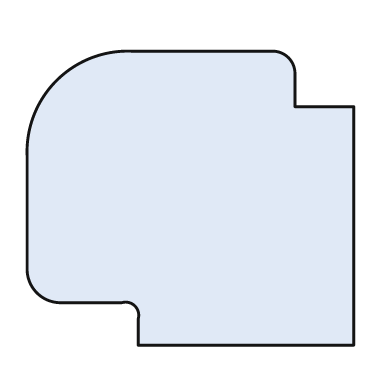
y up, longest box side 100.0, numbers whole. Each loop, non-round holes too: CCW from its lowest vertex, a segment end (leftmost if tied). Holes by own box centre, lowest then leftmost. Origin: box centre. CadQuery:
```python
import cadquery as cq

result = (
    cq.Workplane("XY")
    .moveTo(-16.0, -45.0)
    .lineTo(50.0, -45.0)
    .lineTo(50.0, 28.0)
    .lineTo(32.0, 28.0)
    .lineTo(32.0, 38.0)
    .threePointArc((30.0, 43.0), (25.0, 45.0))
    .lineTo(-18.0, 45.0)
    .threePointArc((-41.0, 36.0), (-50.0, 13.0))
    .lineTo(-50.0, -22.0)
    .threePointArc((-47.0, -29.0), (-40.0, -32.0))
    .lineTo(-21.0, -32.0)
    .threePointArc((-17.0, -33.0), (-16.0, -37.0))
    .close()
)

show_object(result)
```